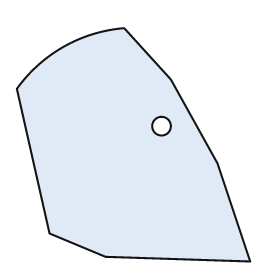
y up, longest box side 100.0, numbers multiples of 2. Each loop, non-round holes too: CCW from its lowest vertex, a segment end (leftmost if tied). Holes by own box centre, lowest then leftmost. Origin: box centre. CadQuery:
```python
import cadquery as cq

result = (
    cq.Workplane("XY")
    .moveTo(50.0, -50.0)
    .lineTo(36.0, -8.0)
    .lineTo(16.0, 28.0)
    .lineTo(-4.0, 50.0)
    .threePointArc((-30.0, 42.0), (-50.0, 24.0))
    .lineTo(-36.0, -38.0)
    .lineTo(-12.0, -48.0)
    .close()
    .moveTo(12.0, 8.0)
    .circle(4.0)
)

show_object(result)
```